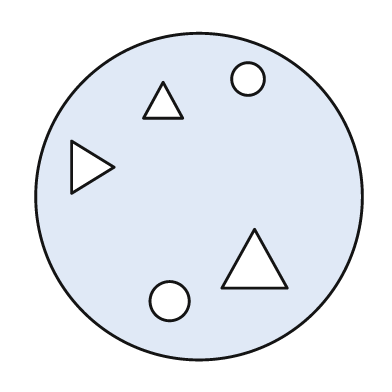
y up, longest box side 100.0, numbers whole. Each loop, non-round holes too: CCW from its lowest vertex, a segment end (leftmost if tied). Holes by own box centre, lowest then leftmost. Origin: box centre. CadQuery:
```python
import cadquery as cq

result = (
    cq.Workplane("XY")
    .moveTo(0.0, 0.0)
    .circle(50.0)
    .moveTo(-9.0, -32.0)
    .circle(6.0)
    .moveTo(7.0, -28.0)
    .lineTo(27.0, -28.0)
    .lineTo(17.0, -10.0)
    .close()
    .moveTo(-39.0, 1.0)
    .lineTo(-26.0, 9.0)
    .lineTo(-39.0, 17.0)
    .close()
    .moveTo(-17.0, 24.0)
    .lineTo(-5.0, 24.0)
    .lineTo(-11.0, 35.0)
    .close()
    .moveTo(15.0, 36.0)
    .circle(5.0)
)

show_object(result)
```